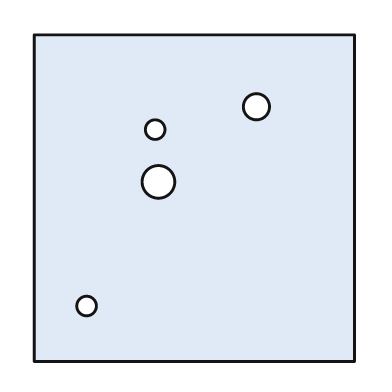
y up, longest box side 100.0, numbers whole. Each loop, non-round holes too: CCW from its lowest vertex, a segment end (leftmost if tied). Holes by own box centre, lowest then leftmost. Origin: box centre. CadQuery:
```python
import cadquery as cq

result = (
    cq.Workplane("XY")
    .moveTo(-49.0, -50.0)
    .lineTo(49.0, -50.0)
    .lineTo(49.0, 50.0)
    .lineTo(-49.0, 50.0)
    .close()
    .moveTo(-33.0, -33.0)
    .circle(3.0)
    .moveTo(-11.0, 5.0)
    .circle(5.0)
    .moveTo(-12.0, 21.0)
    .circle(3.0)
    .moveTo(19.0, 28.0)
    .circle(4.0)
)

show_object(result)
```